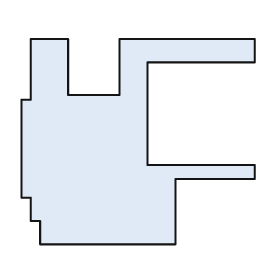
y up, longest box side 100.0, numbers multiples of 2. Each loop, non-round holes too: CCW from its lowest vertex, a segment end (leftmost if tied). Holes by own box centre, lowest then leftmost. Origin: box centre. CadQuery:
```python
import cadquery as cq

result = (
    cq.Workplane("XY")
    .moveTo(-42.0, -44.0)
    .lineTo(16.0, -44.0)
    .lineTo(16.0, -16.0)
    .lineTo(50.0, -16.0)
    .lineTo(50.0, -10.0)
    .lineTo(4.0, -10.0)
    .lineTo(4.0, 34.0)
    .lineTo(50.0, 34.0)
    .lineTo(50.0, 44.0)
    .lineTo(-8.0, 44.0)
    .lineTo(-8.0, 20.0)
    .lineTo(-30.0, 20.0)
    .lineTo(-30.0, 44.0)
    .lineTo(-46.0, 44.0)
    .lineTo(-46.0, 18.0)
    .lineTo(-50.0, 18.0)
    .lineTo(-50.0, -24.0)
    .lineTo(-46.0, -24.0)
    .lineTo(-46.0, -34.0)
    .lineTo(-42.0, -34.0)
    .close()
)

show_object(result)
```